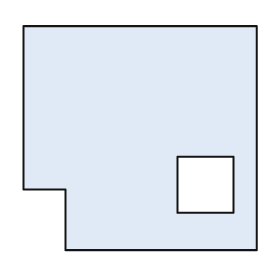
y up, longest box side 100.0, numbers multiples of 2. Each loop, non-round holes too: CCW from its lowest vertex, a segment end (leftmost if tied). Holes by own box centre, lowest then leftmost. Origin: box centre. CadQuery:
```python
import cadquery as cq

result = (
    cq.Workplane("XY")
    .moveTo(-32.0, -48.0)
    .lineTo(50.0, -48.0)
    .lineTo(50.0, 48.0)
    .lineTo(-50.0, 48.0)
    .lineTo(-50.0, -22.0)
    .lineTo(-32.0, -22.0)
    .close()
    .moveTo(16.0, -32.0)
    .lineTo(40.0, -32.0)
    .lineTo(40.0, -8.0)
    .lineTo(16.0, -8.0)
    .close()
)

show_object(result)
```